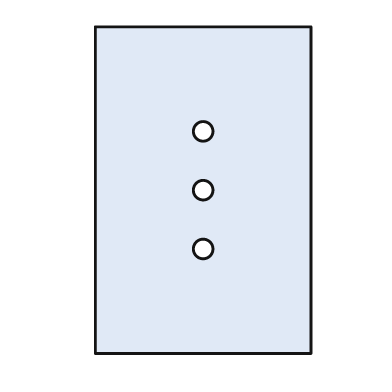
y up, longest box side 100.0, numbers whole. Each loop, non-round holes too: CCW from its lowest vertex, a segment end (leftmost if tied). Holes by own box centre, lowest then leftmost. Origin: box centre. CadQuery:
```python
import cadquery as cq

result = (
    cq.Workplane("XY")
    .moveTo(-33.0, -50.0)
    .lineTo(33.0, -50.0)
    .lineTo(33.0, 50.0)
    .lineTo(-33.0, 50.0)
    .close()
    .moveTo(0.0, -18.0)
    .circle(3.0)
    .moveTo(0.0, 0.0)
    .circle(3.0)
    .moveTo(0.0, 18.0)
    .circle(3.0)
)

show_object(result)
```